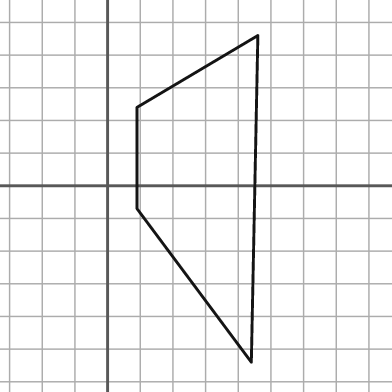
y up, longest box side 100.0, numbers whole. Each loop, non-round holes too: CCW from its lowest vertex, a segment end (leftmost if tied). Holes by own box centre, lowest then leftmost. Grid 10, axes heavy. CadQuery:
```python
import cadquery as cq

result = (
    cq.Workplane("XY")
    .moveTo(44.0, -54.0)
    .lineTo(46.0, 46.0)
    .lineTo(9.0, 24.0)
    .lineTo(9.0, -7.0)
    .close()
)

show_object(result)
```